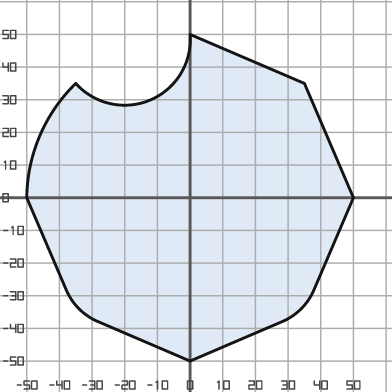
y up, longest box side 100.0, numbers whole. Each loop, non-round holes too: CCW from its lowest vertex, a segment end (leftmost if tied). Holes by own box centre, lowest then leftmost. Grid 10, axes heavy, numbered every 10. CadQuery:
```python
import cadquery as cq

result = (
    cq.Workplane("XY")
    .moveTo(0.0, -50.0)
    .lineTo(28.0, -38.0)
    .threePointArc((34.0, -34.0), (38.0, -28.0))
    .lineTo(50.0, 0.0)
    .lineTo(35.0, 35.0)
    .lineTo(0.0, 50.0)
    .threePointArc((-12.0, 30.0), (-35.0, 35.0))
    .threePointArc((-46.0, 19.0), (-50.0, 0.0))
    .lineTo(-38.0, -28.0)
    .threePointArc((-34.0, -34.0), (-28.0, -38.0))
    .close()
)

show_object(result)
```